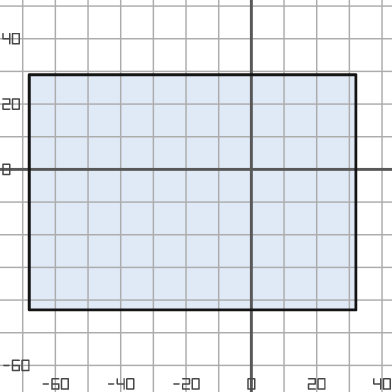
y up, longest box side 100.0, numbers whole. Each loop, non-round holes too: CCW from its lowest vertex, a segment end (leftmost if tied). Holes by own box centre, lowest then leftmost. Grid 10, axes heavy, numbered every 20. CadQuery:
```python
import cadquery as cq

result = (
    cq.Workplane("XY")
    .moveTo(-68.0, -43.0)
    .lineTo(32.0, -43.0)
    .lineTo(32.0, 29.0)
    .lineTo(-68.0, 29.0)
    .close()
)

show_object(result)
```